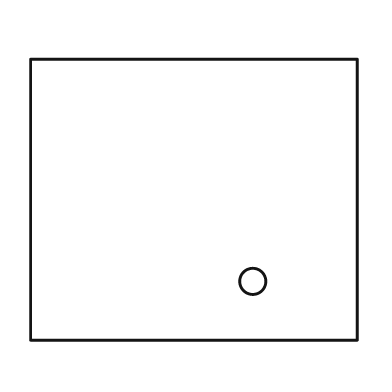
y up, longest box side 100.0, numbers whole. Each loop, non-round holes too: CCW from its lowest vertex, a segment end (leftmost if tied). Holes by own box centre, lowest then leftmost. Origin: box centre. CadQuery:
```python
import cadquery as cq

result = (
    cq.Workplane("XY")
    .moveTo(-50.0, -43.0)
    .lineTo(50.0, -43.0)
    .lineTo(50.0, 43.0)
    .lineTo(-50.0, 43.0)
    .close()
    .moveTo(18.0, -25.0)
    .circle(4.0)
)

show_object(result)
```